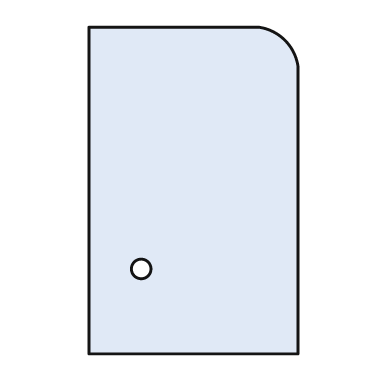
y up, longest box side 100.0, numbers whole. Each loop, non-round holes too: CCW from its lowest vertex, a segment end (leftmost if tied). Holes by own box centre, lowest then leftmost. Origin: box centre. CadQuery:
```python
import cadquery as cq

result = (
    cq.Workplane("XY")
    .moveTo(-32.0, -50.0)
    .lineTo(32.0, -50.0)
    .lineTo(32.0, 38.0)
    .threePointArc((28.0, 46.0), (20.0, 50.0))
    .lineTo(-32.0, 50.0)
    .close()
    .moveTo(-16.0, -24.0)
    .circle(3.0)
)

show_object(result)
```